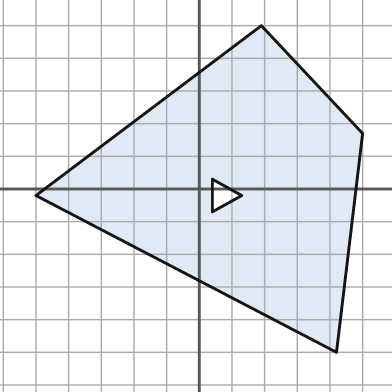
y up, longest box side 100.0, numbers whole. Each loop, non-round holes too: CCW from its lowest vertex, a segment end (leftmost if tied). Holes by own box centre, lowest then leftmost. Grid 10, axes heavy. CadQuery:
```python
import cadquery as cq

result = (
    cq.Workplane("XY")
    .moveTo(42.0, -50.0)
    .lineTo(50.0, 17.0)
    .lineTo(19.0, 50.0)
    .lineTo(-50.0, -2.0)
    .close()
    .moveTo(4.0, -7.0)
    .lineTo(13.0, -2.0)
    .lineTo(4.0, 3.0)
    .close()
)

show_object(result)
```